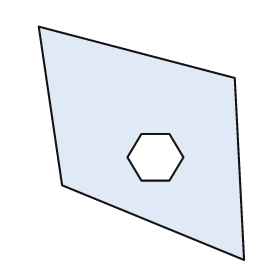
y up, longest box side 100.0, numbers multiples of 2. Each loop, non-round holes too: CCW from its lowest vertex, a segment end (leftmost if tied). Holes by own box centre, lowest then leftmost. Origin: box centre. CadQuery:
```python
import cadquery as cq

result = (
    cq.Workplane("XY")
    .moveTo(44.0, -50.0)
    .lineTo(40.0, 28.0)
    .lineTo(-44.0, 50.0)
    .lineTo(-34.0, -18.0)
    .close()
    .moveTo(0.0, -16.0)
    .lineTo(12.0, -16.0)
    .lineTo(18.0, -6.0)
    .lineTo(12.0, 4.0)
    .lineTo(0.0, 4.0)
    .lineTo(-6.0, -6.0)
    .close()
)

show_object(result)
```